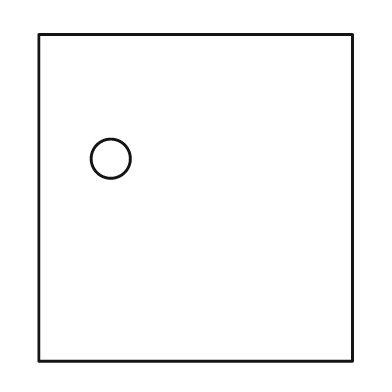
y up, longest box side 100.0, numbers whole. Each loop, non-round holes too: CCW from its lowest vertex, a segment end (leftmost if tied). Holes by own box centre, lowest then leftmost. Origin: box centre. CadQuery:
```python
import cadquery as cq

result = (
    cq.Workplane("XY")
    .moveTo(-48.0, -50.0)
    .lineTo(48.0, -50.0)
    .lineTo(48.0, 50.0)
    .lineTo(-48.0, 50.0)
    .close()
    .moveTo(-26.0, 12.0)
    .circle(6.0)
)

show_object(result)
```